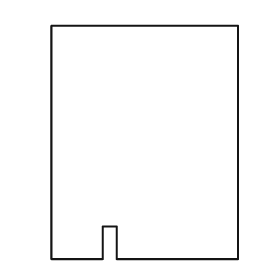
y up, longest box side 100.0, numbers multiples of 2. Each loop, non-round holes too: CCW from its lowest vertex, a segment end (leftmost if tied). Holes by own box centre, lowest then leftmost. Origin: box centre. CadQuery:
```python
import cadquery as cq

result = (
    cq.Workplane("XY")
    .moveTo(-40.0, -50.0)
    .lineTo(-18.0, -50.0)
    .lineTo(-18.0, -36.0)
    .lineTo(-12.0, -36.0)
    .lineTo(-12.0, -50.0)
    .lineTo(40.0, -50.0)
    .lineTo(40.0, 50.0)
    .lineTo(-40.0, 50.0)
    .close()
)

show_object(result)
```